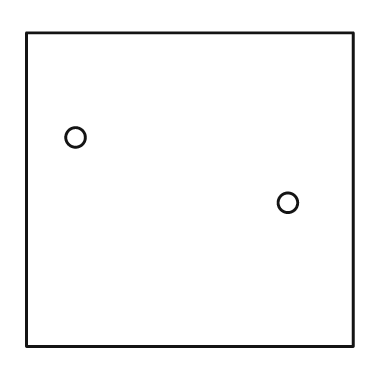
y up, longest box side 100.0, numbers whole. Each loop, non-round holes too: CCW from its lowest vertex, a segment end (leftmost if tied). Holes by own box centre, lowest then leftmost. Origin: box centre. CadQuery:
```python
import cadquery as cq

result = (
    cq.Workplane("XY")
    .moveTo(-50.0, -48.0)
    .lineTo(50.0, -48.0)
    .lineTo(50.0, 48.0)
    .lineTo(-50.0, 48.0)
    .close()
    .moveTo(30.0, -4.0)
    .circle(3.0)
    .moveTo(-35.0, 16.0)
    .circle(3.0)
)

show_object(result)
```